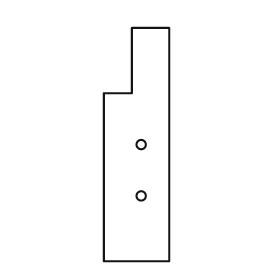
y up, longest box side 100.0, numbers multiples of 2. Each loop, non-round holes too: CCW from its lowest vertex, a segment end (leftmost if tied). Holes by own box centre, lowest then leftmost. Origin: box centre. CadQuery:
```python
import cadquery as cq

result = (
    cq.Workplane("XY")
    .moveTo(-14.0, -50.0)
    .lineTo(14.0, -50.0)
    .lineTo(14.0, 50.0)
    .lineTo(-2.0, 50.0)
    .lineTo(-2.0, 22.0)
    .lineTo(-14.0, 22.0)
    .close()
    .moveTo(2.0, -22.0)
    .circle(2.0)
    .moveTo(2.0, 0.0)
    .circle(2.0)
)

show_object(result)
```